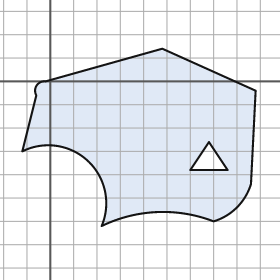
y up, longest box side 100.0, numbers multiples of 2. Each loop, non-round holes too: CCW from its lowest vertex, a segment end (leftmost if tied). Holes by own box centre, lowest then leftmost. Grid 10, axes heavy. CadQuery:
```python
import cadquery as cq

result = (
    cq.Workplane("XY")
    .moveTo(22.0, -62.0)
    .threePointArc((46.0, -56.0), (70.0, -60.0))
    .threePointArc((80.0, -54.0), (86.0, -44.0))
    .lineTo(88.0, -4.0)
    .lineTo(48.0, 14.0)
    .lineTo(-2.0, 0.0)
    .threePointArc((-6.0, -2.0), (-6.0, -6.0))
    .lineTo(-12.0, -30.0)
    .threePointArc((16.0, -34.0), (22.0, -62.0))
    .close()
    .moveTo(60.0, -38.0)
    .lineTo(76.0, -38.0)
    .lineTo(68.0, -26.0)
    .close()
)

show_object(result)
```